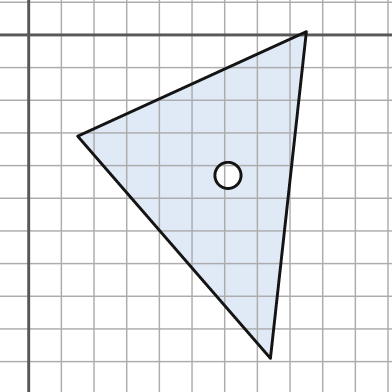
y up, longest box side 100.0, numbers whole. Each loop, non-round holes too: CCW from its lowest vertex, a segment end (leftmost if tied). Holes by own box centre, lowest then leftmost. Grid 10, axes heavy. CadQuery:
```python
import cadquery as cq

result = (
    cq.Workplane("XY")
    .moveTo(74.0, -99.0)
    .lineTo(85.0, 1.0)
    .lineTo(15.0, -31.0)
    .close()
    .moveTo(61.0, -43.0)
    .circle(4.0)
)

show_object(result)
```